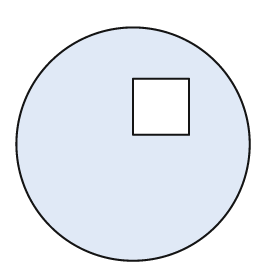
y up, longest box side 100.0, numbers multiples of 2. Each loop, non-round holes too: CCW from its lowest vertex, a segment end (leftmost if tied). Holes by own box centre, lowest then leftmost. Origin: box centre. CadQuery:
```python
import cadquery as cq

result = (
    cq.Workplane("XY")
    .moveTo(0.0, 0.0)
    .circle(50.0)
    .moveTo(0.0, 4.0)
    .lineTo(24.0, 4.0)
    .lineTo(24.0, 28.0)
    .lineTo(0.0, 28.0)
    .close()
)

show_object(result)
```